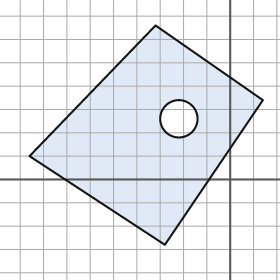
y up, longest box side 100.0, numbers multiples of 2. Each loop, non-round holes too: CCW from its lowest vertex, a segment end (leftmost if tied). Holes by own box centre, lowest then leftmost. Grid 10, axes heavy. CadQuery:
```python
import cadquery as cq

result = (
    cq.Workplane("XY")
    .moveTo(-28.0, -28.0)
    .lineTo(14.0, 34.0)
    .lineTo(-32.0, 66.0)
    .lineTo(-86.0, 10.0)
    .close()
    .moveTo(-22.0, 26.0)
    .circle(8.0)
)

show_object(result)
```